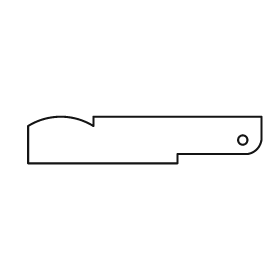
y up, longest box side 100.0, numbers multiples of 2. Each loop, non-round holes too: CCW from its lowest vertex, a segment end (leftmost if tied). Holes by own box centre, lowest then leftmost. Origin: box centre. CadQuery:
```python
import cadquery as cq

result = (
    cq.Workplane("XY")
    .moveTo(-50.0, -10.0)
    .lineTo(14.0, -10.0)
    .lineTo(14.0, -6.0)
    .lineTo(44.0, -6.0)
    .threePointArc((48.0, -4.0), (50.0, 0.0))
    .lineTo(50.0, 10.0)
    .lineTo(-22.0, 10.0)
    .lineTo(-22.0, 6.0)
    .threePointArc((-36.0, 10.0), (-50.0, 6.0))
    .close()
    .moveTo(42.0, 0.0)
    .circle(2.0)
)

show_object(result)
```